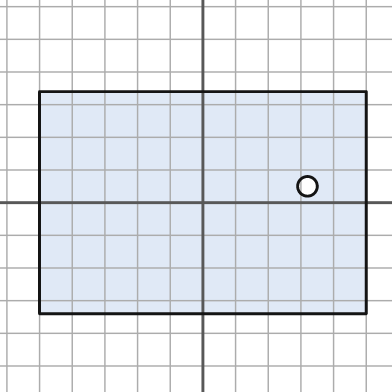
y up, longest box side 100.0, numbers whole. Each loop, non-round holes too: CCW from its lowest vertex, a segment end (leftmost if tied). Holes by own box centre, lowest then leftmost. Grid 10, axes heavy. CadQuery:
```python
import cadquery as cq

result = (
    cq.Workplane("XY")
    .moveTo(-50.0, -34.0)
    .lineTo(50.0, -34.0)
    .lineTo(50.0, 34.0)
    .lineTo(-50.0, 34.0)
    .close()
    .moveTo(32.0, 5.0)
    .circle(3.0)
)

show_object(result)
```